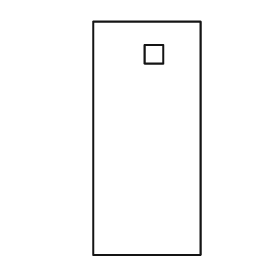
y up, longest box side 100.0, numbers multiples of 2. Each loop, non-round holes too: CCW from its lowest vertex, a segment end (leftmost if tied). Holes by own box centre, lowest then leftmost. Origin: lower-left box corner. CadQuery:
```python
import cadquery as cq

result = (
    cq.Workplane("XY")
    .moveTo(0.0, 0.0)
    .lineTo(46.0, 0.0)
    .lineTo(46.0, 100.0)
    .lineTo(0.0, 100.0)
    .close()
    .moveTo(22.0, 82.0)
    .lineTo(30.0, 82.0)
    .lineTo(30.0, 90.0)
    .lineTo(22.0, 90.0)
    .close()
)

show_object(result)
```